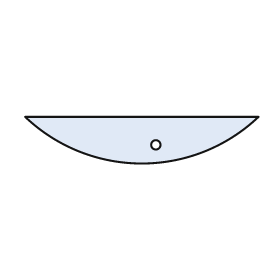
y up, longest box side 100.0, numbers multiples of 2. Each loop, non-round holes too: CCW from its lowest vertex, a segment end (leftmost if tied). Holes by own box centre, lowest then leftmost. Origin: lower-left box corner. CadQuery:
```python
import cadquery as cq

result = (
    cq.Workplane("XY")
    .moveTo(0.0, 20.0)
    .threePointArc((50.0, 0.0), (100.0, 20.0))
    .close()
    .moveTo(56.0, 8.0)
    .circle(2.0)
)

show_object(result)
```